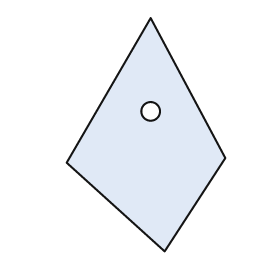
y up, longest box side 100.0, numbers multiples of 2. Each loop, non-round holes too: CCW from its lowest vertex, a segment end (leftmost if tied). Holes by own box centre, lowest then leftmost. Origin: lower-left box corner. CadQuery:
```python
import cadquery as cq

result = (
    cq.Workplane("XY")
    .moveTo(42.0, 0.0)
    .lineTo(68.0, 40.0)
    .lineTo(36.0, 100.0)
    .lineTo(0.0, 38.0)
    .close()
    .moveTo(36.0, 60.0)
    .circle(4.0)
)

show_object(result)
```